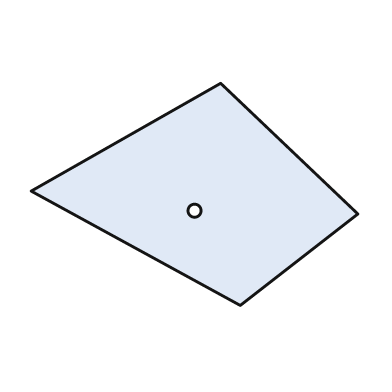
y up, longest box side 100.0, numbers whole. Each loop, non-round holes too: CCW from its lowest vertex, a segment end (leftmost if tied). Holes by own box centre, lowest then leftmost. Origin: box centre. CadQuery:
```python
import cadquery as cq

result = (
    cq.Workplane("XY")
    .moveTo(14.0, -34.0)
    .lineTo(50.0, -6.0)
    .lineTo(8.0, 34.0)
    .lineTo(-50.0, 1.0)
    .close()
    .moveTo(0.0, -5.0)
    .circle(2.0)
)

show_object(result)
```